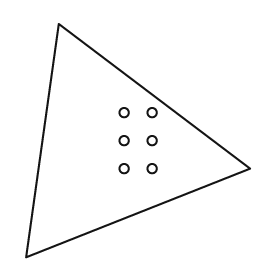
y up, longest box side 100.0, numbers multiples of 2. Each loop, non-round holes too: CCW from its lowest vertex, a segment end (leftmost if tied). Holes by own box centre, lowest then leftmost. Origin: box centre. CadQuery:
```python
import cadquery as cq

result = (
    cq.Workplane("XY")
    .moveTo(-48.0, -50.0)
    .lineTo(48.0, -12.0)
    .lineTo(-34.0, 50.0)
    .close()
    .moveTo(-6.0, -12.0)
    .circle(2.0)
    .moveTo(6.0, -12.0)
    .circle(2.0)
    .moveTo(-6.0, 0.0)
    .circle(2.0)
    .moveTo(6.0, 0.0)
    .circle(2.0)
    .moveTo(-6.0, 12.0)
    .circle(2.0)
    .moveTo(6.0, 12.0)
    .circle(2.0)
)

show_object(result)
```